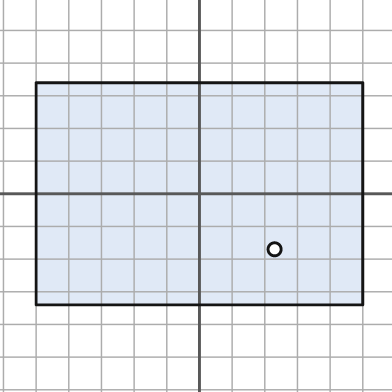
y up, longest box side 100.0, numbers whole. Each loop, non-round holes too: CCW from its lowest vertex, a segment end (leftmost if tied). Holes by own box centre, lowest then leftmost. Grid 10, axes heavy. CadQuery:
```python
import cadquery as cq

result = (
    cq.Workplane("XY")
    .moveTo(-50.0, -34.0)
    .lineTo(50.0, -34.0)
    .lineTo(50.0, 34.0)
    .lineTo(-50.0, 34.0)
    .close()
    .moveTo(23.0, -17.0)
    .circle(2.0)
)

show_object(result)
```